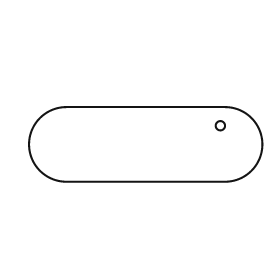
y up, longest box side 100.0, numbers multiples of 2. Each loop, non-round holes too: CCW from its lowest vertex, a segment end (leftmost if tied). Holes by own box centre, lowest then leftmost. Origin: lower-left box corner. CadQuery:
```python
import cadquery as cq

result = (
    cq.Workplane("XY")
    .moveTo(16.0, 0.0)
    .lineTo(84.0, 0.0)
    .threePointArc((100.0, 16.0), (84.0, 32.0))
    .lineTo(16.0, 32.0)
    .threePointArc((0.0, 16.0), (16.0, 0.0))
    .close()
    .moveTo(82.0, 24.0)
    .circle(2.0)
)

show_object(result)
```